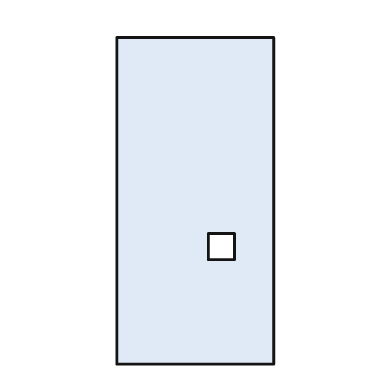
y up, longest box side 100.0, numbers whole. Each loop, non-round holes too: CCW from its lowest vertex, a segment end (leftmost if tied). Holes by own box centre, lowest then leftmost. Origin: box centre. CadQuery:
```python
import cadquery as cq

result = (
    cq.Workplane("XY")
    .moveTo(-24.0, -50.0)
    .lineTo(24.0, -50.0)
    .lineTo(24.0, 50.0)
    .lineTo(-24.0, 50.0)
    .close()
    .moveTo(4.0, -18.0)
    .lineTo(12.0, -18.0)
    .lineTo(12.0, -10.0)
    .lineTo(4.0, -10.0)
    .close()
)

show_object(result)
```